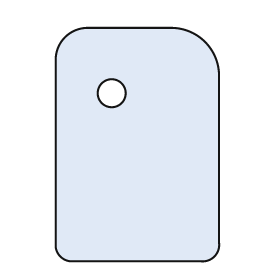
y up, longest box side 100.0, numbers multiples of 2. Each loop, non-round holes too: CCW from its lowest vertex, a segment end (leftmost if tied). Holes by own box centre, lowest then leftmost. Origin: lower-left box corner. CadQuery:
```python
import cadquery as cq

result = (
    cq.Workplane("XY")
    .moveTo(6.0, 0.0)
    .lineTo(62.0, 0.0)
    .threePointArc((68.0, 2.0), (70.0, 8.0))
    .lineTo(70.0, 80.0)
    .threePointArc((64.0, 94.0), (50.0, 100.0))
    .lineTo(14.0, 100.0)
    .threePointArc((4.0, 96.0), (0.0, 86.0))
    .lineTo(0.0, 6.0)
    .threePointArc((2.0, 2.0), (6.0, 0.0))
    .close()
    .moveTo(24.0, 72.0)
    .circle(6.0)
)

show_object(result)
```